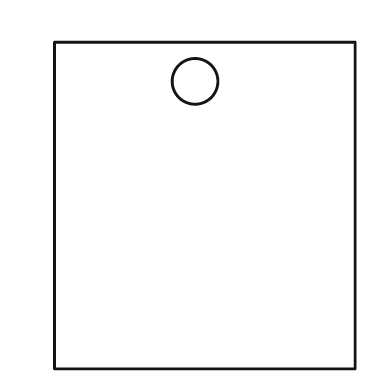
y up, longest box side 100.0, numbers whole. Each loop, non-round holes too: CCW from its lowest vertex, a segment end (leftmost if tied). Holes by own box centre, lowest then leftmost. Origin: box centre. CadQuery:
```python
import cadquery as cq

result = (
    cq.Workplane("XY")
    .moveTo(-46.0, -50.0)
    .lineTo(46.0, -50.0)
    .lineTo(46.0, 50.0)
    .lineTo(-46.0, 50.0)
    .close()
    .moveTo(-3.0, 38.0)
    .circle(7.0)
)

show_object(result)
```